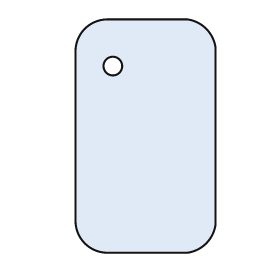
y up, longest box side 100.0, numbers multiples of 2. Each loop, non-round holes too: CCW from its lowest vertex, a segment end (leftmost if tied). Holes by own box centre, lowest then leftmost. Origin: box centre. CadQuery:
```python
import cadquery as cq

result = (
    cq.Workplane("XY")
    .moveTo(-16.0, -50.0)
    .lineTo(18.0, -50.0)
    .threePointArc((26.0, -46.0), (30.0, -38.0))
    .lineTo(30.0, 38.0)
    .threePointArc((26.0, 46.0), (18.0, 50.0))
    .lineTo(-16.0, 50.0)
    .threePointArc((-26.0, 46.0), (-30.0, 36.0))
    .lineTo(-30.0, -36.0)
    .threePointArc((-26.0, -46.0), (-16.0, -50.0))
    .close()
    .moveTo(-14.0, 30.0)
    .circle(4.0)
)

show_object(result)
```